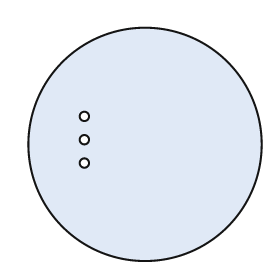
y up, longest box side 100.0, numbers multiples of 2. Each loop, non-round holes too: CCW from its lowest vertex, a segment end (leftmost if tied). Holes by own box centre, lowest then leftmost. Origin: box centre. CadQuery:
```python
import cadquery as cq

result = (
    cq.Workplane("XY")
    .moveTo(0.0, 0.0)
    .circle(50.0)
    .moveTo(-26.0, -8.0)
    .circle(2.0)
    .moveTo(-26.0, 2.0)
    .circle(2.0)
    .moveTo(-26.0, 12.0)
    .circle(2.0)
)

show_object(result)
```